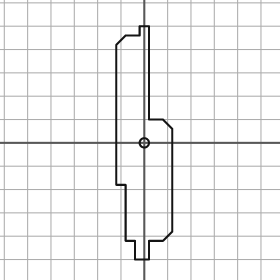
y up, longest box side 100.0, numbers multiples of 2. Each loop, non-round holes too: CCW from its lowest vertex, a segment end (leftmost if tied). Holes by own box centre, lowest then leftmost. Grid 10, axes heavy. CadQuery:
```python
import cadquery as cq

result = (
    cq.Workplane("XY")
    .moveTo(-4.0, -50.0)
    .lineTo(2.0, -50.0)
    .lineTo(2.0, -42.0)
    .lineTo(8.0, -42.0)
    .lineTo(12.0, -38.0)
    .lineTo(12.0, 6.0)
    .lineTo(8.0, 10.0)
    .lineTo(2.0, 10.0)
    .lineTo(2.0, 50.0)
    .lineTo(-2.0, 50.0)
    .lineTo(-2.0, 46.0)
    .lineTo(-8.0, 46.0)
    .lineTo(-12.0, 42.0)
    .lineTo(-12.0, -18.0)
    .lineTo(-8.0, -18.0)
    .lineTo(-8.0, -42.0)
    .lineTo(-4.0, -42.0)
    .close()
    .moveTo(0.0, 0.0)
    .circle(2.0)
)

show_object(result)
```